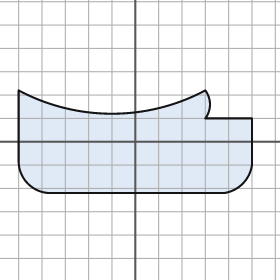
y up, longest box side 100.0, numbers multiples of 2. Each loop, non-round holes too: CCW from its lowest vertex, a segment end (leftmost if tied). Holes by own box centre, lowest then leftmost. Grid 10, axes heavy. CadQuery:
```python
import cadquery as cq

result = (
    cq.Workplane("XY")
    .moveTo(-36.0, -22.0)
    .lineTo(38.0, -22.0)
    .threePointArc((46.0, -18.0), (50.0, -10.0))
    .lineTo(50.0, 10.0)
    .lineTo(30.0, 10.0)
    .threePointArc((32.0, 16.0), (30.0, 22.0))
    .threePointArc((-10.0, 12.0), (-50.0, 22.0))
    .lineTo(-50.0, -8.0)
    .threePointArc((-46.0, -18.0), (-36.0, -22.0))
    .close()
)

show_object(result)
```